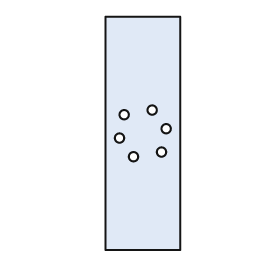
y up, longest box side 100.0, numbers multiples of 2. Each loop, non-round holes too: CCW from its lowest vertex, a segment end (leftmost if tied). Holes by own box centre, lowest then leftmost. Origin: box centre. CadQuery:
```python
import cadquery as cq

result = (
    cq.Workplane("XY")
    .moveTo(-16.0, -50.0)
    .lineTo(16.0, -50.0)
    .lineTo(16.0, 50.0)
    .lineTo(-16.0, 50.0)
    .close()
    .moveTo(-4.0, -10.0)
    .circle(2.0)
    .moveTo(8.0, -8.0)
    .circle(2.0)
    .moveTo(-10.0, -2.0)
    .circle(2.0)
    .moveTo(10.0, 2.0)
    .circle(2.0)
    .moveTo(-8.0, 8.0)
    .circle(2.0)
    .moveTo(4.0, 10.0)
    .circle(2.0)
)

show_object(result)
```